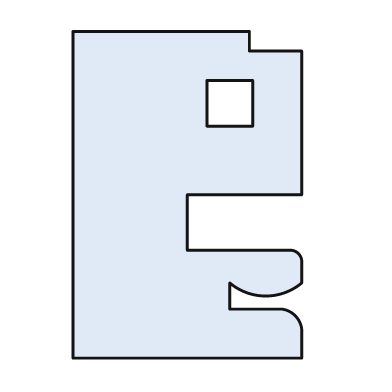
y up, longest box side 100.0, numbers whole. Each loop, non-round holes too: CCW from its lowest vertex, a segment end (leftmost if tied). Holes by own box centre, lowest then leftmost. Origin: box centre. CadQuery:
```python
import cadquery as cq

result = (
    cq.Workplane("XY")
    .moveTo(-35.0, -50.0)
    .lineTo(35.0, -50.0)
    .lineTo(35.0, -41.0)
    .threePointArc((33.0, -37.0), (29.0, -35.0))
    .lineTo(13.0, -35.0)
    .lineTo(13.0, -27.0)
    .threePointArc((24.0, -31.0), (35.0, -27.0))
    .lineTo(35.0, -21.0)
    .threePointArc((34.0, -18.0), (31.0, -17.0))
    .lineTo(0.0, -17.0)
    .lineTo(0.0, 0.0)
    .lineTo(35.0, 0.0)
    .lineTo(35.0, 44.0)
    .lineTo(19.0, 44.0)
    .lineTo(19.0, 50.0)
    .lineTo(-35.0, 50.0)
    .close()
    .moveTo(6.0, 21.0)
    .lineTo(20.0, 21.0)
    .lineTo(20.0, 35.0)
    .lineTo(6.0, 35.0)
    .close()
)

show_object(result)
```